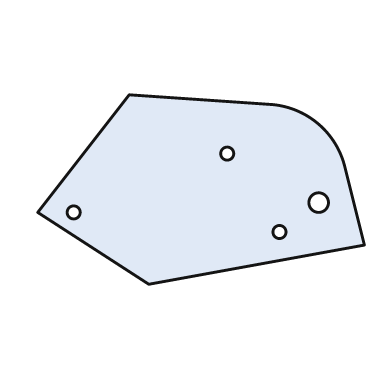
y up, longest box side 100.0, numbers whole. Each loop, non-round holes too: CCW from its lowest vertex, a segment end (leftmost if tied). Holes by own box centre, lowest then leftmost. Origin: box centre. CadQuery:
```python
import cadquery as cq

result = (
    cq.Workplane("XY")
    .moveTo(-16.0, -29.0)
    .lineTo(50.0, -17.0)
    .lineTo(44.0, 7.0)
    .threePointArc((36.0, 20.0), (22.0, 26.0))
    .lineTo(-22.0, 29.0)
    .lineTo(-50.0, -7.0)
    .close()
    .moveTo(24.0, -13.0)
    .circle(2.0)
    .moveTo(-39.0, -7.0)
    .circle(2.0)
    .moveTo(36.0, -4.0)
    .circle(3.0)
    .moveTo(8.0, 11.0)
    .circle(2.0)
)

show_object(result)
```